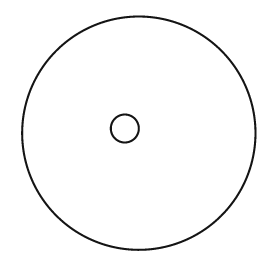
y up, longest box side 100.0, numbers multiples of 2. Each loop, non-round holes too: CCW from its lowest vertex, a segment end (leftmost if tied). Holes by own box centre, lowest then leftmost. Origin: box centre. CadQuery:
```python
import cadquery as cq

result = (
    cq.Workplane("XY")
    .moveTo(0.0, 0.0)
    .circle(50.0)
    .moveTo(-6.0, 2.0)
    .circle(6.0)
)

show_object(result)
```